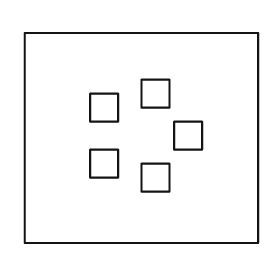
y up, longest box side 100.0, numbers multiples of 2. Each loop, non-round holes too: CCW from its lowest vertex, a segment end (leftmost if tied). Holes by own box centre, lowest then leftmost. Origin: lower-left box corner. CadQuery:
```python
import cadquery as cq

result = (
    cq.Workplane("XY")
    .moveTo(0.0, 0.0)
    .lineTo(100.0, 0.0)
    .lineTo(100.0, 90.0)
    .lineTo(0.0, 90.0)
    .close()
    .moveTo(50.0, 22.0)
    .lineTo(62.0, 22.0)
    .lineTo(62.0, 34.0)
    .lineTo(50.0, 34.0)
    .close()
    .moveTo(28.0, 28.0)
    .lineTo(40.0, 28.0)
    .lineTo(40.0, 40.0)
    .lineTo(28.0, 40.0)
    .close()
    .moveTo(64.0, 40.0)
    .lineTo(76.0, 40.0)
    .lineTo(76.0, 52.0)
    .lineTo(64.0, 52.0)
    .close()
    .moveTo(28.0, 52.0)
    .lineTo(40.0, 52.0)
    .lineTo(40.0, 64.0)
    .lineTo(28.0, 64.0)
    .close()
    .moveTo(50.0, 58.0)
    .lineTo(62.0, 58.0)
    .lineTo(62.0, 70.0)
    .lineTo(50.0, 70.0)
    .close()
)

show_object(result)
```